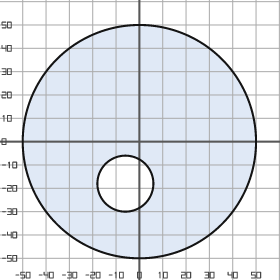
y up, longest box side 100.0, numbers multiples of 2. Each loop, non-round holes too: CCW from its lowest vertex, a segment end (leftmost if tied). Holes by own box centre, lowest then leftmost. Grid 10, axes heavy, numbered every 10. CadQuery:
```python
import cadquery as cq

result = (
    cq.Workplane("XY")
    .moveTo(0.0, 0.0)
    .circle(50.0)
    .moveTo(-6.0, -18.0)
    .circle(12.0)
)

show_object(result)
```